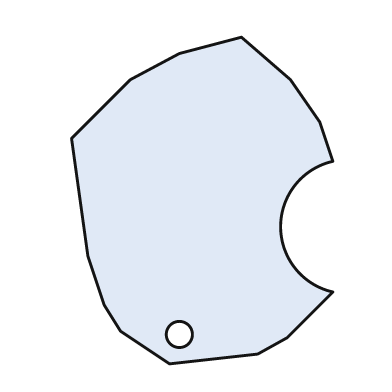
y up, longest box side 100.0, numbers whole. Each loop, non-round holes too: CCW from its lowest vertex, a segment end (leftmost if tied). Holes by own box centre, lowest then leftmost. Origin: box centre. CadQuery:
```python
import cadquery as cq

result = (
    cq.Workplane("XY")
    .moveTo(-10.0, -50.0)
    .lineTo(17.0, -47.0)
    .lineTo(26.0, -42.0)
    .lineTo(40.0, -28.0)
    .threePointArc((24.0, -8.0), (40.0, 12.0))
    .lineTo(36.0, 24.0)
    .lineTo(27.0, 37.0)
    .lineTo(12.0, 50.0)
    .lineTo(-7.0, 45.0)
    .lineTo(-22.0, 37.0)
    .lineTo(-40.0, 19.0)
    .lineTo(-35.0, -17.0)
    .lineTo(-30.0, -32.0)
    .lineTo(-25.0, -40.0)
    .close()
    .moveTo(-7.0, -41.0)
    .circle(4.0)
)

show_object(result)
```